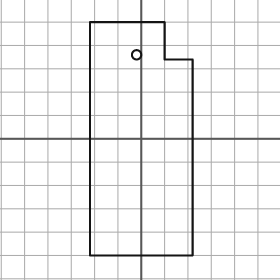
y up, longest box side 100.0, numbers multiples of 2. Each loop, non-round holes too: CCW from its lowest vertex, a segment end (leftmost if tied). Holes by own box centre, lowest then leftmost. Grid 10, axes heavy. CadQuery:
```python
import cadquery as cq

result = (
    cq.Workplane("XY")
    .moveTo(-22.0, -50.0)
    .lineTo(22.0, -50.0)
    .lineTo(22.0, 34.0)
    .lineTo(10.0, 34.0)
    .lineTo(10.0, 50.0)
    .lineTo(-22.0, 50.0)
    .close()
    .moveTo(-2.0, 36.0)
    .circle(2.0)
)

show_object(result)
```